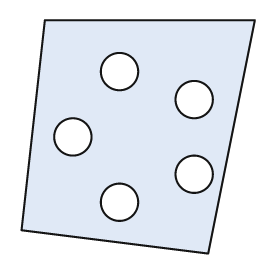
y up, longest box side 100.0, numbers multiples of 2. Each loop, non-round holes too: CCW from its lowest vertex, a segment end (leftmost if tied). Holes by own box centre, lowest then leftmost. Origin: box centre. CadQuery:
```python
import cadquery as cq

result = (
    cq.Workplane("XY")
    .moveTo(30.0, -50.0)
    .lineTo(50.0, 50.0)
    .lineTo(-40.0, 50.0)
    .lineTo(-50.0, -40.0)
    .close()
    .moveTo(-8.0, -28.0)
    .circle(8.0)
    .moveTo(24.0, -16.0)
    .circle(8.0)
    .moveTo(-28.0, 0.0)
    .circle(8.0)
    .moveTo(24.0, 16.0)
    .circle(8.0)
    .moveTo(-8.0, 28.0)
    .circle(8.0)
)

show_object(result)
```